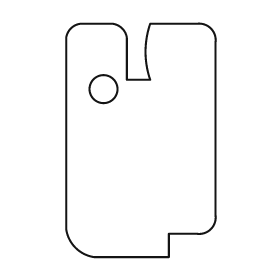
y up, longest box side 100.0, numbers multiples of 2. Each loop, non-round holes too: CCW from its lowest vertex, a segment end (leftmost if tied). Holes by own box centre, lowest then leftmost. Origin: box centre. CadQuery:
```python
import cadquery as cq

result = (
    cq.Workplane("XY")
    .moveTo(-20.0, -50.0)
    .lineTo(12.0, -50.0)
    .lineTo(12.0, -40.0)
    .lineTo(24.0, -40.0)
    .threePointArc((30.0, -38.0), (32.0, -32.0))
    .lineTo(32.0, 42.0)
    .threePointArc((30.0, 48.0), (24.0, 50.0))
    .lineTo(4.0, 50.0)
    .threePointArc((2.0, 38.0), (4.0, 26.0))
    .lineTo(-6.0, 26.0)
    .lineTo(-6.0, 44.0)
    .threePointArc((-8.0, 48.0), (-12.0, 50.0))
    .lineTo(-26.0, 50.0)
    .threePointArc((-30.0, 48.0), (-32.0, 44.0))
    .lineTo(-32.0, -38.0)
    .threePointArc((-28.0, -46.0), (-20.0, -50.0))
    .close()
    .moveTo(-16.0, 22.0)
    .circle(6.0)
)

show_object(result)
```